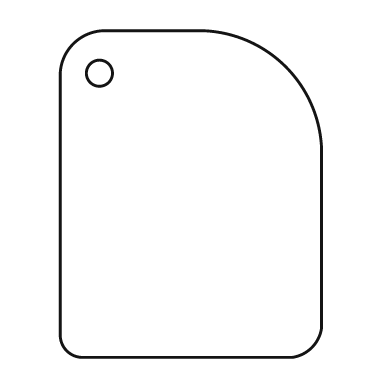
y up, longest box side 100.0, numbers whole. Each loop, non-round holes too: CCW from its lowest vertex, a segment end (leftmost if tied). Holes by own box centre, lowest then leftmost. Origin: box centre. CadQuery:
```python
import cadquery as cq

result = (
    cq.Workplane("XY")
    .moveTo(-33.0, -50.0)
    .lineTo(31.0, -50.0)
    .threePointArc((37.0, -47.0), (40.0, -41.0))
    .lineTo(40.0, 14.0)
    .threePointArc((29.0, 39.0), (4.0, 50.0))
    .lineTo(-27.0, 50.0)
    .threePointArc((-36.0, 46.0), (-40.0, 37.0))
    .lineTo(-40.0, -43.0)
    .threePointArc((-38.0, -48.0), (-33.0, -50.0))
    .close()
    .moveTo(-28.0, 37.0)
    .circle(4.0)
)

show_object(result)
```